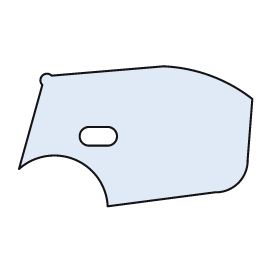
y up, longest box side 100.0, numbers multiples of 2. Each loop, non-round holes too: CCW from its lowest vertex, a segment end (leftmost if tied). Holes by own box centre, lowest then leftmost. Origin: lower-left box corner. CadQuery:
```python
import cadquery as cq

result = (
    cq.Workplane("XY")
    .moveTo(38.0, 0.0)
    .lineTo(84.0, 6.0)
    .threePointArc((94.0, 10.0), (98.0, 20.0))
    .lineTo(100.0, 46.0)
    .threePointArc((82.0, 56.0), (62.0, 60.0))
    .lineTo(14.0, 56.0)
    .threePointArc((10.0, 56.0), (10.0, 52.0))
    .lineTo(0.0, 16.0)
    .threePointArc((24.0, 20.0), (38.0, 0.0))
    .close()
    .moveTo(30.0, 26.0)
    .lineTo(38.0, 26.0)
    .threePointArc((42.0, 30.0), (38.0, 34.0))
    .lineTo(30.0, 34.0)
    .threePointArc((26.0, 30.0), (30.0, 26.0))
    .close()
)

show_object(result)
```